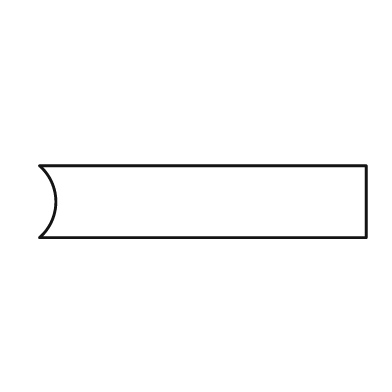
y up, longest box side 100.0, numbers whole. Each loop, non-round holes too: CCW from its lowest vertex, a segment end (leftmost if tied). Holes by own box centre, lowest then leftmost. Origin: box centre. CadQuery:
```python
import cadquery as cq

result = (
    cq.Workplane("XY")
    .moveTo(-50.0, -11.0)
    .lineTo(50.0, -11.0)
    .lineTo(50.0, 11.0)
    .lineTo(-50.0, 11.0)
    .threePointArc((-45.0, 0.0), (-50.0, -11.0))
    .close()
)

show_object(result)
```